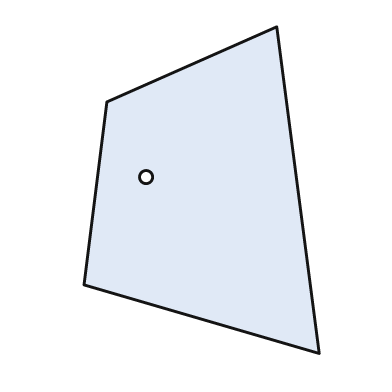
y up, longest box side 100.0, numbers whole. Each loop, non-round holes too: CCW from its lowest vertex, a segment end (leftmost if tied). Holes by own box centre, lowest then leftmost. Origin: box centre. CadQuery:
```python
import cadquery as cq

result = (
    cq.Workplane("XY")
    .moveTo(36.0, -50.0)
    .lineTo(23.0, 50.0)
    .lineTo(-29.0, 27.0)
    .lineTo(-36.0, -29.0)
    .close()
    .moveTo(-17.0, 4.0)
    .circle(2.0)
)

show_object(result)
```